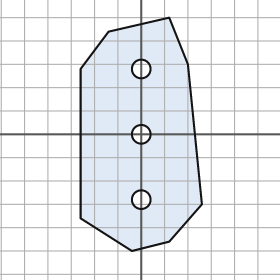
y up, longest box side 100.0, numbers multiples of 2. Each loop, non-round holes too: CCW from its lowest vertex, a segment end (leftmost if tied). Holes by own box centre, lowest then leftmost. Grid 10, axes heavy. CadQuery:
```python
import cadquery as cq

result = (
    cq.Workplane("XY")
    .moveTo(-4.0, -50.0)
    .lineTo(12.0, -46.0)
    .lineTo(26.0, -30.0)
    .lineTo(20.0, 30.0)
    .lineTo(12.0, 50.0)
    .lineTo(-14.0, 44.0)
    .lineTo(-26.0, 28.0)
    .lineTo(-26.0, -36.0)
    .close()
    .moveTo(0.0, -28.0)
    .circle(4.0)
    .moveTo(0.0, 0.0)
    .circle(4.0)
    .moveTo(0.0, 28.0)
    .circle(4.0)
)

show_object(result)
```